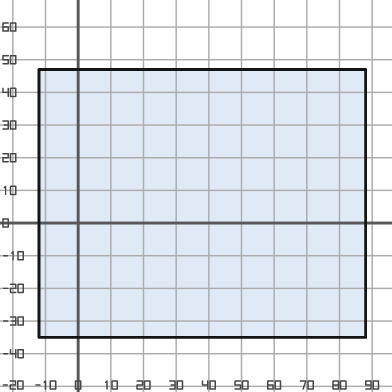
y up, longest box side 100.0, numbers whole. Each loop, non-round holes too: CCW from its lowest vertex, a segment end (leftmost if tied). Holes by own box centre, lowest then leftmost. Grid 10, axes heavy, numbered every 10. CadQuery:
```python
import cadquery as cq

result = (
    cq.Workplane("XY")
    .moveTo(-12.0, -35.0)
    .lineTo(88.0, -35.0)
    .lineTo(88.0, 47.0)
    .lineTo(-12.0, 47.0)
    .close()
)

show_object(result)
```